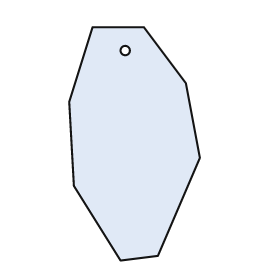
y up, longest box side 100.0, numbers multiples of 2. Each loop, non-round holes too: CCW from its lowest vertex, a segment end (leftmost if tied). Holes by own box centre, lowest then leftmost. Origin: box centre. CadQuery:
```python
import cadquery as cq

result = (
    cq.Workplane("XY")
    .moveTo(-6.0, -50.0)
    .lineTo(10.0, -48.0)
    .lineTo(28.0, -6.0)
    .lineTo(22.0, 26.0)
    .lineTo(4.0, 50.0)
    .lineTo(-18.0, 50.0)
    .lineTo(-28.0, 18.0)
    .lineTo(-26.0, -18.0)
    .close()
    .moveTo(-4.0, 40.0)
    .circle(2.0)
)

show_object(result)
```